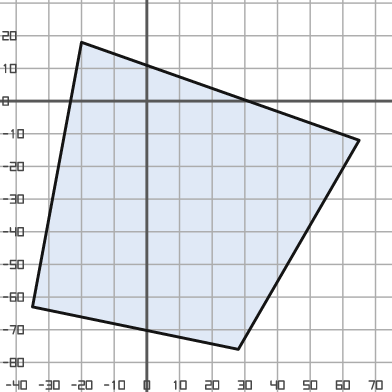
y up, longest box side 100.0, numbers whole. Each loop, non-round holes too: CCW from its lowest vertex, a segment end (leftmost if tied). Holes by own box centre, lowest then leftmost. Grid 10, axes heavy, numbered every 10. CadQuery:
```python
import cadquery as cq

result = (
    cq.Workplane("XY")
    .moveTo(28.0, -76.0)
    .lineTo(65.0, -12.0)
    .lineTo(-20.0, 18.0)
    .lineTo(-35.0, -63.0)
    .close()
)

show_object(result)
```